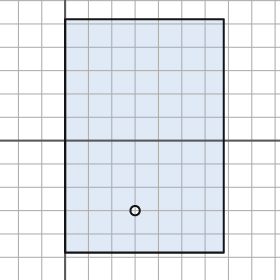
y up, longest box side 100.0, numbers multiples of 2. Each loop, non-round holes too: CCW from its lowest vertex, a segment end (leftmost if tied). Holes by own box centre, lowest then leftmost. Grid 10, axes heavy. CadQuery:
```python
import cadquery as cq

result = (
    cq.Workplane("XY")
    .moveTo(0.0, -48.0)
    .lineTo(68.0, -48.0)
    .lineTo(68.0, 52.0)
    .lineTo(0.0, 52.0)
    .close()
    .moveTo(30.0, -30.0)
    .circle(2.0)
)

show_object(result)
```